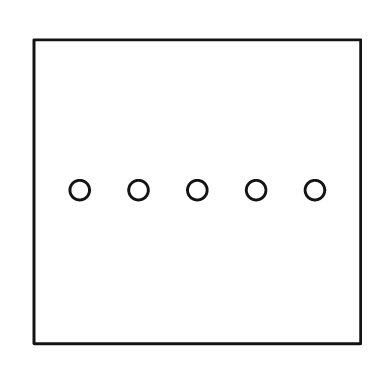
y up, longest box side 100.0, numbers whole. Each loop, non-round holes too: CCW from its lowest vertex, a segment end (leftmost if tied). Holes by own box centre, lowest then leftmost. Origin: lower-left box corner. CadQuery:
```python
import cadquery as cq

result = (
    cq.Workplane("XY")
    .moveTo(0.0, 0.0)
    .lineTo(100.0, 0.0)
    .lineTo(100.0, 93.0)
    .lineTo(0.0, 93.0)
    .close()
    .moveTo(14.0, 47.0)
    .circle(3.0)
    .moveTo(32.0, 47.0)
    .circle(3.0)
    .moveTo(50.0, 47.0)
    .circle(3.0)
    .moveTo(68.0, 47.0)
    .circle(3.0)
    .moveTo(86.0, 47.0)
    .circle(3.0)
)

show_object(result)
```